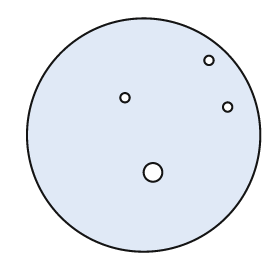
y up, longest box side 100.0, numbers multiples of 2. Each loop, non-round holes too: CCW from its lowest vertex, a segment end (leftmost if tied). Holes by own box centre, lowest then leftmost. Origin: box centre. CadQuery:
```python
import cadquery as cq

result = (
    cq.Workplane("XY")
    .moveTo(0.0, 0.0)
    .circle(50.0)
    .moveTo(4.0, -16.0)
    .circle(4.0)
    .moveTo(36.0, 12.0)
    .circle(2.0)
    .moveTo(-8.0, 16.0)
    .circle(2.0)
    .moveTo(28.0, 32.0)
    .circle(2.0)
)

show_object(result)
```